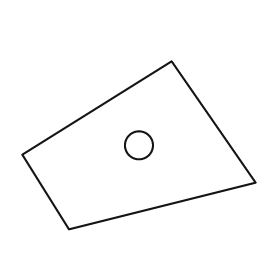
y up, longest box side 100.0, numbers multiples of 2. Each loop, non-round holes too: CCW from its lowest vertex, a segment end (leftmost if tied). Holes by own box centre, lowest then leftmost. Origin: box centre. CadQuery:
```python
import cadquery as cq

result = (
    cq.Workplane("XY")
    .moveTo(-30.0, -36.0)
    .lineTo(50.0, -16.0)
    .lineTo(14.0, 36.0)
    .lineTo(-50.0, -4.0)
    .close()
    .moveTo(0.0, 0.0)
    .circle(6.0)
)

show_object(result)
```